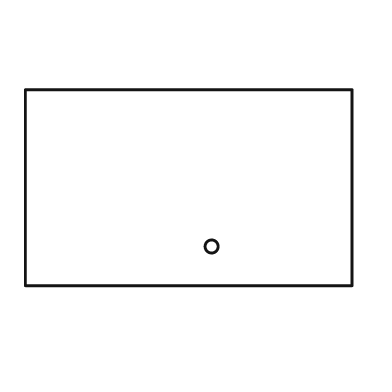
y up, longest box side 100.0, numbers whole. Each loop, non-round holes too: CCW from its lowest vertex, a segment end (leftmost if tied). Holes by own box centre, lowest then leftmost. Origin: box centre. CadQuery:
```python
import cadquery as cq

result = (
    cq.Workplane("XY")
    .moveTo(-50.0, -30.0)
    .lineTo(50.0, -30.0)
    .lineTo(50.0, 30.0)
    .lineTo(-50.0, 30.0)
    .close()
    .moveTo(7.0, -18.0)
    .circle(2.0)
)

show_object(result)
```